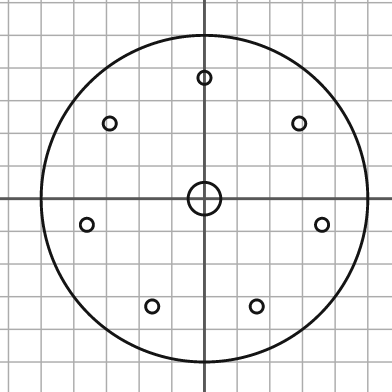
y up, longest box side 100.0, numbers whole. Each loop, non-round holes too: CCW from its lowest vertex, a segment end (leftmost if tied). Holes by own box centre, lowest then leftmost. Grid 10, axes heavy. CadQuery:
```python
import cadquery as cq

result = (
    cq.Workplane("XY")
    .moveTo(0.0, 0.0)
    .circle(50.0)
    .moveTo(-16.0, -33.0)
    .circle(2.0)
    .moveTo(16.0, -33.0)
    .circle(2.0)
    .moveTo(-36.0, -8.0)
    .circle(2.0)
    .moveTo(36.0, -8.0)
    .circle(2.0)
    .moveTo(0.0, 0.0)
    .circle(5.0)
    .moveTo(-29.0, 23.0)
    .circle(2.0)
    .moveTo(29.0, 23.0)
    .circle(2.0)
    .moveTo(0.0, 37.0)
    .circle(2.0)
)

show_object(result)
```